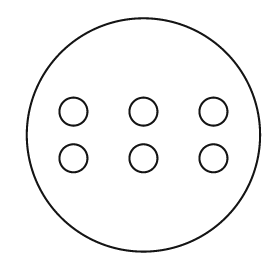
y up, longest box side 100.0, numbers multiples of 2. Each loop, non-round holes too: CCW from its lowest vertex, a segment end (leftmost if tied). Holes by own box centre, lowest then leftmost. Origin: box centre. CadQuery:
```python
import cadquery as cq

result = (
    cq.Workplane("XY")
    .moveTo(0.0, 0.0)
    .circle(50.0)
    .moveTo(-30.0, -10.0)
    .circle(6.0)
    .moveTo(0.0, -10.0)
    .circle(6.0)
    .moveTo(30.0, -10.0)
    .circle(6.0)
    .moveTo(-30.0, 10.0)
    .circle(6.0)
    .moveTo(0.0, 10.0)
    .circle(6.0)
    .moveTo(30.0, 10.0)
    .circle(6.0)
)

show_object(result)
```